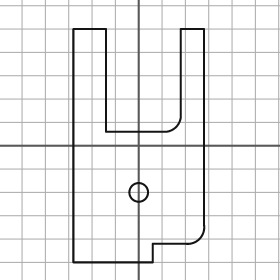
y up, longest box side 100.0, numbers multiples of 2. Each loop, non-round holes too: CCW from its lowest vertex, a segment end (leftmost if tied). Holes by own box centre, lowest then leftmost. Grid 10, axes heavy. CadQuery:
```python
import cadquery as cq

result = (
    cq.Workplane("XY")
    .moveTo(-28.0, -50.0)
    .lineTo(6.0, -50.0)
    .lineTo(6.0, -42.0)
    .lineTo(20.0, -42.0)
    .threePointArc((26.0, -40.0), (28.0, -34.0))
    .lineTo(28.0, 50.0)
    .lineTo(18.0, 50.0)
    .lineTo(18.0, 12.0)
    .threePointArc((16.0, 8.0), (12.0, 6.0))
    .lineTo(-14.0, 6.0)
    .lineTo(-14.0, 50.0)
    .lineTo(-28.0, 50.0)
    .close()
    .moveTo(0.0, -20.0)
    .circle(4.0)
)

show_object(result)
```